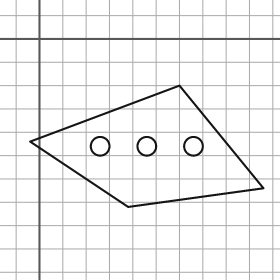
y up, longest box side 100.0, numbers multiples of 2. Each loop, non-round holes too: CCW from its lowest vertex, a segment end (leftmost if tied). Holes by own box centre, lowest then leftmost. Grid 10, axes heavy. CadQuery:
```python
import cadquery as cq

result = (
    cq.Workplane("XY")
    .moveTo(38.0, -72.0)
    .lineTo(96.0, -64.0)
    .lineTo(60.0, -20.0)
    .lineTo(-4.0, -44.0)
    .close()
    .moveTo(26.0, -46.0)
    .circle(4.0)
    .moveTo(46.0, -46.0)
    .circle(4.0)
    .moveTo(66.0, -46.0)
    .circle(4.0)
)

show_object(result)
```